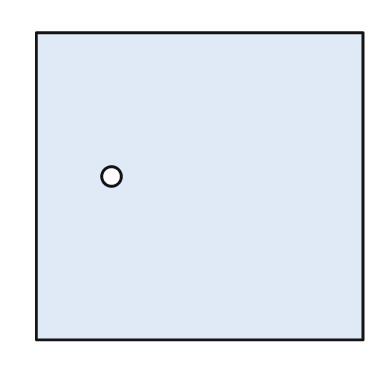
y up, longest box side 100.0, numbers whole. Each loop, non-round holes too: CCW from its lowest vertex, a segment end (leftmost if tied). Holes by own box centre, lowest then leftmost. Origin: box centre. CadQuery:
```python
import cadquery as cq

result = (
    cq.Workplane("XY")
    .moveTo(-50.0, -47.0)
    .lineTo(50.0, -47.0)
    .lineTo(50.0, 47.0)
    .lineTo(-50.0, 47.0)
    .close()
    .moveTo(-27.0, 3.0)
    .circle(3.0)
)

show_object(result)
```